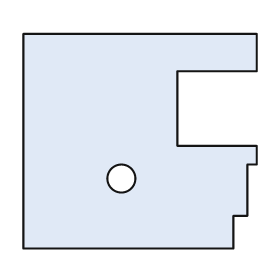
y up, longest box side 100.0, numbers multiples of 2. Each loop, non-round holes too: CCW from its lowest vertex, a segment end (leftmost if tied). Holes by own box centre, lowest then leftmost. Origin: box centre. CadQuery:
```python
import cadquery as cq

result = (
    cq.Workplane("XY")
    .moveTo(-50.0, -46.0)
    .lineTo(40.0, -46.0)
    .lineTo(40.0, -32.0)
    .lineTo(46.0, -32.0)
    .lineTo(46.0, -10.0)
    .lineTo(50.0, -10.0)
    .lineTo(50.0, -2.0)
    .lineTo(16.0, -2.0)
    .lineTo(16.0, 30.0)
    .lineTo(50.0, 30.0)
    .lineTo(50.0, 46.0)
    .lineTo(-50.0, 46.0)
    .close()
    .moveTo(-8.0, -16.0)
    .circle(6.0)
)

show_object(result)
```